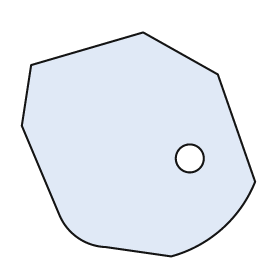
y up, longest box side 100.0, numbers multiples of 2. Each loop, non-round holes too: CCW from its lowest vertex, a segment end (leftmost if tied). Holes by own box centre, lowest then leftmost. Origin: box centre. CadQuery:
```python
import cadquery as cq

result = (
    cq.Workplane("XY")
    .moveTo(14.0, -48.0)
    .threePointArc((36.0, -36.0), (50.0, -16.0))
    .lineTo(34.0, 30.0)
    .lineTo(2.0, 48.0)
    .lineTo(-46.0, 34.0)
    .lineTo(-50.0, 8.0)
    .lineTo(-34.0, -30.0)
    .threePointArc((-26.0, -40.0), (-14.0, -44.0))
    .close()
    .moveTo(22.0, -6.0)
    .circle(6.0)
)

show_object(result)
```